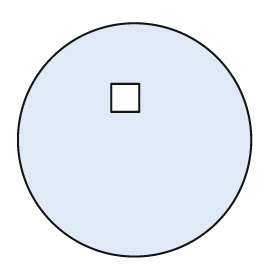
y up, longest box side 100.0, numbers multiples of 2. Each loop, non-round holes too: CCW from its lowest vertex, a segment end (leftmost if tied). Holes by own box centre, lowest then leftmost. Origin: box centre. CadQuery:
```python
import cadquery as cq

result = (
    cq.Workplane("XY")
    .moveTo(0.0, 0.0)
    .circle(50.0)
    .moveTo(-10.0, 12.0)
    .lineTo(2.0, 12.0)
    .lineTo(2.0, 24.0)
    .lineTo(-10.0, 24.0)
    .close()
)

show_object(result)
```